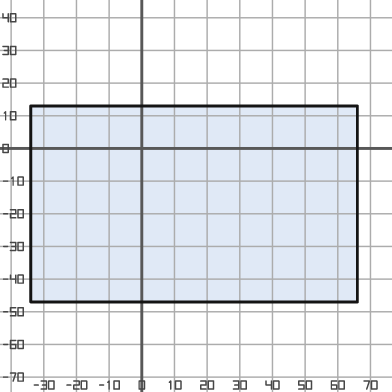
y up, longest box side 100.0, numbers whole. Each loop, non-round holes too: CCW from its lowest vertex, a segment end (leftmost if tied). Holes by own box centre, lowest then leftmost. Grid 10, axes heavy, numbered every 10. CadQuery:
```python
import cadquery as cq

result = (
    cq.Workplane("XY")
    .moveTo(-34.0, -47.0)
    .lineTo(66.0, -47.0)
    .lineTo(66.0, 13.0)
    .lineTo(-34.0, 13.0)
    .close()
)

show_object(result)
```